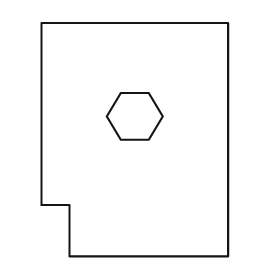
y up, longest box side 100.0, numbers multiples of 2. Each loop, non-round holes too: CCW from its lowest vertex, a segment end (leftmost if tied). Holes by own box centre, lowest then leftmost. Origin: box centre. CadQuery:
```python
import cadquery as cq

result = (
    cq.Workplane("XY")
    .moveTo(-28.0, -50.0)
    .lineTo(40.0, -50.0)
    .lineTo(40.0, 50.0)
    .lineTo(-40.0, 50.0)
    .lineTo(-40.0, -28.0)
    .lineTo(-28.0, -28.0)
    .close()
    .moveTo(-6.0, 0.0)
    .lineTo(6.0, 0.0)
    .lineTo(12.0, 10.0)
    .lineTo(6.0, 20.0)
    .lineTo(-6.0, 20.0)
    .lineTo(-12.0, 10.0)
    .close()
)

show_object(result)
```